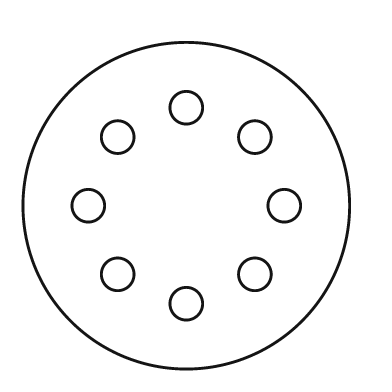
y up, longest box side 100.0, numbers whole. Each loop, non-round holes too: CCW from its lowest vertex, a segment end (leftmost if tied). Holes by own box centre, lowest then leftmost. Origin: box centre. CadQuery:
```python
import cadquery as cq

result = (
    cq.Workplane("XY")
    .moveTo(0.0, 0.0)
    .circle(50.0)
    .moveTo(0.0, -30.0)
    .circle(5.0)
    .moveTo(-21.0, -21.0)
    .circle(5.0)
    .moveTo(21.0, -21.0)
    .circle(5.0)
    .moveTo(-30.0, 0.0)
    .circle(5.0)
    .moveTo(30.0, 0.0)
    .circle(5.0)
    .moveTo(-21.0, 21.0)
    .circle(5.0)
    .moveTo(21.0, 21.0)
    .circle(5.0)
    .moveTo(0.0, 30.0)
    .circle(5.0)
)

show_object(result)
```